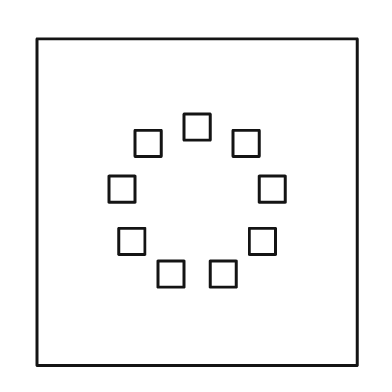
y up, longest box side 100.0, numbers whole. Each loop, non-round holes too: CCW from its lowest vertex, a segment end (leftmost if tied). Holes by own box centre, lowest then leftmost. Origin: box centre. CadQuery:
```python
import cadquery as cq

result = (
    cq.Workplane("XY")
    .moveTo(-49.0, -50.0)
    .lineTo(49.0, -50.0)
    .lineTo(49.0, 50.0)
    .lineTo(-49.0, 50.0)
    .close()
    .moveTo(-12.0, -26.0)
    .lineTo(-4.0, -26.0)
    .lineTo(-4.0, -18.0)
    .lineTo(-12.0, -18.0)
    .close()
    .moveTo(4.0, -26.0)
    .lineTo(12.0, -26.0)
    .lineTo(12.0, -18.0)
    .lineTo(4.0, -18.0)
    .close()
    .moveTo(-24.0, -16.0)
    .lineTo(-16.0, -16.0)
    .lineTo(-16.0, -8.0)
    .lineTo(-24.0, -8.0)
    .close()
    .moveTo(16.0, -16.0)
    .lineTo(24.0, -16.0)
    .lineTo(24.0, -8.0)
    .lineTo(16.0, -8.0)
    .close()
    .moveTo(-27.0, 0.0)
    .lineTo(-19.0, 0.0)
    .lineTo(-19.0, 8.0)
    .lineTo(-27.0, 8.0)
    .close()
    .moveTo(19.0, 0.0)
    .lineTo(27.0, 0.0)
    .lineTo(27.0, 8.0)
    .lineTo(19.0, 8.0)
    .close()
    .moveTo(-19.0, 14.0)
    .lineTo(-11.0, 14.0)
    .lineTo(-11.0, 22.0)
    .lineTo(-19.0, 22.0)
    .close()
    .moveTo(11.0, 14.0)
    .lineTo(19.0, 14.0)
    .lineTo(19.0, 22.0)
    .lineTo(11.0, 22.0)
    .close()
    .moveTo(-4.0, 19.0)
    .lineTo(4.0, 19.0)
    .lineTo(4.0, 27.0)
    .lineTo(-4.0, 27.0)
    .close()
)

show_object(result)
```